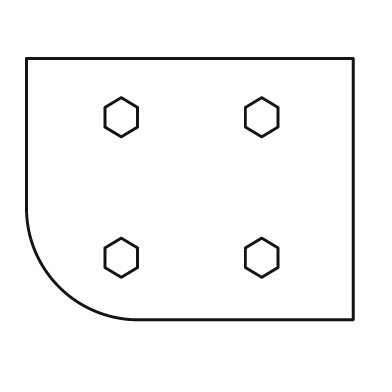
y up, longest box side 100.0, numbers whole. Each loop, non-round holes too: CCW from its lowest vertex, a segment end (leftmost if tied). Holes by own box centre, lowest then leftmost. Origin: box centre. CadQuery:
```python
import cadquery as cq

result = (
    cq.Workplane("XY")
    .moveTo(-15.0, -40.0)
    .lineTo(50.0, -40.0)
    .lineTo(50.0, 40.0)
    .lineTo(-50.0, 40.0)
    .lineTo(-50.0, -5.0)
    .threePointArc((-40.0, -30.0), (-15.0, -40.0))
    .close()
    .moveTo(-21.0, -27.0)
    .lineTo(-16.0, -24.0)
    .lineTo(-16.0, -18.0)
    .lineTo(-21.0, -15.0)
    .lineTo(-26.0, -18.0)
    .lineTo(-26.0, -24.0)
    .close()
    .moveTo(22.0, -27.0)
    .lineTo(27.0, -24.0)
    .lineTo(27.0, -18.0)
    .lineTo(22.0, -15.0)
    .lineTo(17.0, -18.0)
    .lineTo(17.0, -24.0)
    .close()
    .moveTo(-21.0, 16.0)
    .lineTo(-16.0, 19.0)
    .lineTo(-16.0, 25.0)
    .lineTo(-21.0, 28.0)
    .lineTo(-26.0, 25.0)
    .lineTo(-26.0, 19.0)
    .close()
    .moveTo(22.0, 16.0)
    .lineTo(27.0, 19.0)
    .lineTo(27.0, 25.0)
    .lineTo(22.0, 28.0)
    .lineTo(17.0, 25.0)
    .lineTo(17.0, 19.0)
    .close()
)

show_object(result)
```